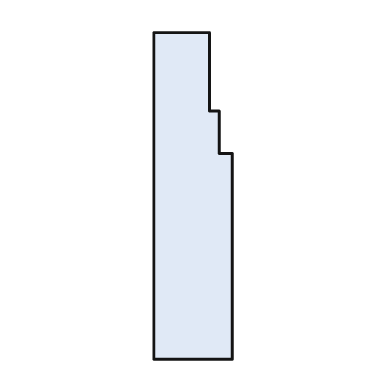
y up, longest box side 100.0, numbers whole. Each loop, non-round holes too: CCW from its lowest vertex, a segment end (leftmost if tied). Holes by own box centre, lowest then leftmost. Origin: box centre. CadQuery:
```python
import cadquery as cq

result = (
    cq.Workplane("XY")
    .moveTo(-12.0, -50.0)
    .lineTo(12.0, -50.0)
    .lineTo(12.0, 13.0)
    .lineTo(8.0, 13.0)
    .lineTo(8.0, 26.0)
    .lineTo(5.0, 26.0)
    .lineTo(5.0, 50.0)
    .lineTo(-12.0, 50.0)
    .close()
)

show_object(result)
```